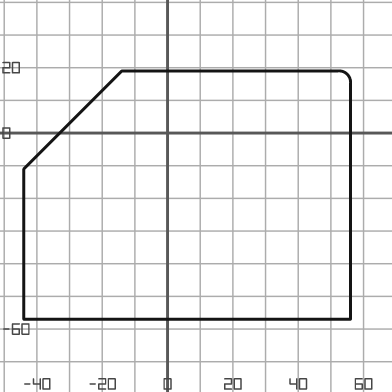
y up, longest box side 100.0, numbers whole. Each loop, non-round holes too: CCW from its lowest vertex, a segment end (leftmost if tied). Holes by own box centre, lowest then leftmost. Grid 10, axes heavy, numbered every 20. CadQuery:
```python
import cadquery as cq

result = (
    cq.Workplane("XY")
    .moveTo(-44.0, -57.0)
    .lineTo(56.0, -57.0)
    .lineTo(56.0, 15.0)
    .threePointArc((55.0, 18.0), (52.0, 19.0))
    .lineTo(-14.0, 19.0)
    .lineTo(-44.0, -11.0)
    .close()
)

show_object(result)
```